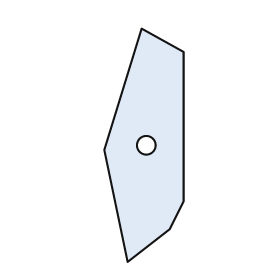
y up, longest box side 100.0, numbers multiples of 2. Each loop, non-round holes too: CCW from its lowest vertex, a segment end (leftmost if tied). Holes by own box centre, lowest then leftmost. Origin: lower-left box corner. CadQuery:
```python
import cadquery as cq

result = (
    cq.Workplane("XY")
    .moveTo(10.0, 0.0)
    .lineTo(28.0, 14.0)
    .lineTo(34.0, 26.0)
    .lineTo(34.0, 90.0)
    .lineTo(16.0, 100.0)
    .lineTo(0.0, 48.0)
    .close()
    .moveTo(18.0, 50.0)
    .circle(4.0)
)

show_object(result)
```